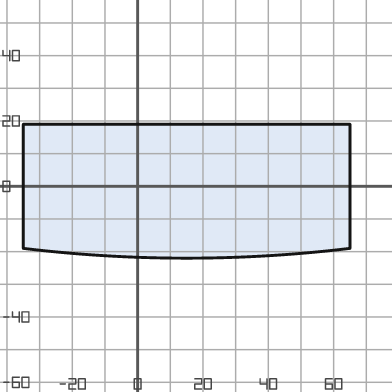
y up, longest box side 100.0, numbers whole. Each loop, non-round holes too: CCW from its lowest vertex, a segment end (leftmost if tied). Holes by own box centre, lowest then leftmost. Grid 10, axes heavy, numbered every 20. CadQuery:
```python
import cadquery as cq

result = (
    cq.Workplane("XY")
    .moveTo(-35.0, -19.0)
    .threePointArc((15.0, -22.0), (65.0, -19.0))
    .lineTo(65.0, 19.0)
    .lineTo(-35.0, 19.0)
    .close()
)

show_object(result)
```